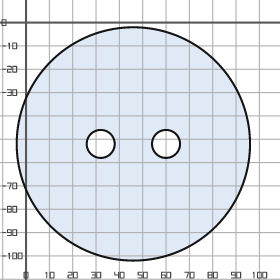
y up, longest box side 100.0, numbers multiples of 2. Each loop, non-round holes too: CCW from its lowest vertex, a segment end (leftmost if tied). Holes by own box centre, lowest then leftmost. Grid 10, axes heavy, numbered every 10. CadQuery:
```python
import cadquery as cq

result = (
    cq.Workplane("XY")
    .moveTo(46.0, -52.0)
    .circle(50.0)
    .moveTo(32.0, -52.0)
    .circle(6.0)
    .moveTo(60.0, -52.0)
    .circle(6.0)
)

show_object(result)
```